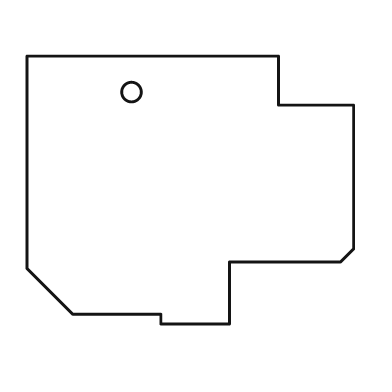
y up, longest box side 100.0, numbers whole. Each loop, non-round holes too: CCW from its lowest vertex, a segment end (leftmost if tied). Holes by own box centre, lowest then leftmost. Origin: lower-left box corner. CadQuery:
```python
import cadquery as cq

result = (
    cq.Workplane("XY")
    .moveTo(41.0, 0.0)
    .lineTo(62.0, 0.0)
    .lineTo(62.0, 19.0)
    .lineTo(96.0, 19.0)
    .lineTo(100.0, 23.0)
    .lineTo(100.0, 67.0)
    .lineTo(77.0, 67.0)
    .lineTo(77.0, 82.0)
    .lineTo(0.0, 82.0)
    .lineTo(0.0, 17.0)
    .lineTo(14.0, 3.0)
    .lineTo(41.0, 3.0)
    .close()
    .moveTo(32.0, 71.0)
    .circle(3.0)
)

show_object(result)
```